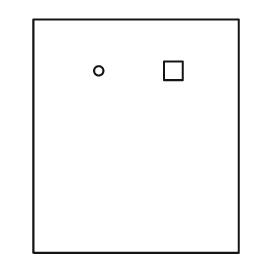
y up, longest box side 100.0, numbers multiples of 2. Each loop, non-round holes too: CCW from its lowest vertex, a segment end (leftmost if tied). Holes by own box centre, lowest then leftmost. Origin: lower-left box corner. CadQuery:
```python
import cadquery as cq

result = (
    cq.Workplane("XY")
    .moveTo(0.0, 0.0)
    .lineTo(88.0, 0.0)
    .lineTo(88.0, 100.0)
    .lineTo(0.0, 100.0)
    .close()
    .moveTo(28.0, 78.0)
    .circle(2.0)
    .moveTo(56.0, 74.0)
    .lineTo(64.0, 74.0)
    .lineTo(64.0, 82.0)
    .lineTo(56.0, 82.0)
    .close()
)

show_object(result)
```